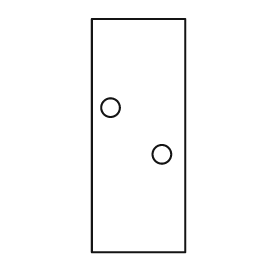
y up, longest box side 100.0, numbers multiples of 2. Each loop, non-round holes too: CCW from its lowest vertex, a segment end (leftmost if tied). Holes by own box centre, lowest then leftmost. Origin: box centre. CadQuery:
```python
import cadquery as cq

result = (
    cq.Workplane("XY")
    .moveTo(-20.0, -50.0)
    .lineTo(20.0, -50.0)
    .lineTo(20.0, 50.0)
    .lineTo(-20.0, 50.0)
    .close()
    .moveTo(10.0, -8.0)
    .circle(4.0)
    .moveTo(-12.0, 12.0)
    .circle(4.0)
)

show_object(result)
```